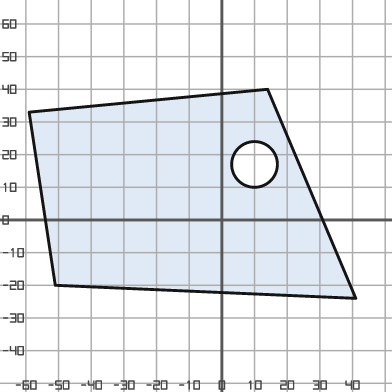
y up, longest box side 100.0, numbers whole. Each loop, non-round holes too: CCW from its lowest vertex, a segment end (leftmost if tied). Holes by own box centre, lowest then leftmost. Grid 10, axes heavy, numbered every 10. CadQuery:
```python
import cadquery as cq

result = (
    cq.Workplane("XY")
    .moveTo(41.0, -24.0)
    .lineTo(14.0, 40.0)
    .lineTo(-59.0, 33.0)
    .lineTo(-51.0, -20.0)
    .close()
    .moveTo(10.0, 17.0)
    .circle(7.0)
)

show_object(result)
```